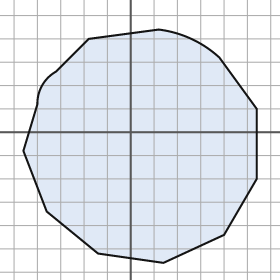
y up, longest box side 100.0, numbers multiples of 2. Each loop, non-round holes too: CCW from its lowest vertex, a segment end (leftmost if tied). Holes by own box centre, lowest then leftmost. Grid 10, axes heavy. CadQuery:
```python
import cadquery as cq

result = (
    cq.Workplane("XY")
    .moveTo(14.0, -56.0)
    .lineTo(40.0, -44.0)
    .lineTo(54.0, -20.0)
    .lineTo(54.0, 10.0)
    .lineTo(38.0, 32.0)
    .threePointArc((26.0, 40.0), (12.0, 44.0))
    .lineTo(-18.0, 40.0)
    .lineTo(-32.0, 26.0)
    .threePointArc((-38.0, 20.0), (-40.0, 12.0))
    .lineTo(-46.0, -8.0)
    .lineTo(-36.0, -34.0)
    .lineTo(-14.0, -52.0)
    .close()
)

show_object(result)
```